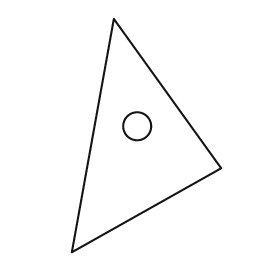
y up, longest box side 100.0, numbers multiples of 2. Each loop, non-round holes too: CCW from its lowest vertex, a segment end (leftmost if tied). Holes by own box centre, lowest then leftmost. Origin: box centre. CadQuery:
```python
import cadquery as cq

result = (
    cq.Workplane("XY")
    .moveTo(-32.0, -50.0)
    .lineTo(32.0, -14.0)
    .lineTo(-14.0, 50.0)
    .close()
    .moveTo(-4.0, 4.0)
    .circle(6.0)
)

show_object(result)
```